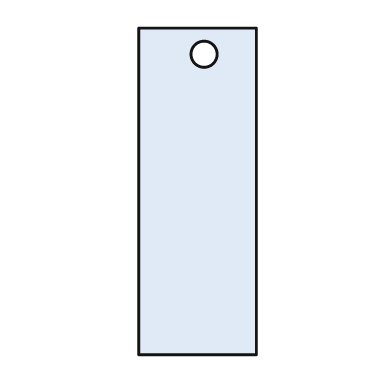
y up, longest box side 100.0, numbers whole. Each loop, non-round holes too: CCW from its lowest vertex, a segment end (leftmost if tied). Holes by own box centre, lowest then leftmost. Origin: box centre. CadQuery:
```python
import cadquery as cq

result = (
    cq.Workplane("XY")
    .moveTo(-18.0, -50.0)
    .lineTo(18.0, -50.0)
    .lineTo(18.0, 50.0)
    .lineTo(-18.0, 50.0)
    .close()
    .moveTo(2.0, 42.0)
    .circle(4.0)
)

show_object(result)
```